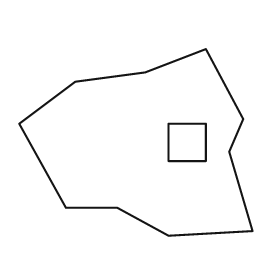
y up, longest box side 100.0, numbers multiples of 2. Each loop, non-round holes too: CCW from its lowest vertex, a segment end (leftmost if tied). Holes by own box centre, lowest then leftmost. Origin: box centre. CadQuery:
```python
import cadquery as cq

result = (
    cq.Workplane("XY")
    .moveTo(14.0, -40.0)
    .lineTo(50.0, -38.0)
    .lineTo(40.0, -4.0)
    .lineTo(46.0, 10.0)
    .lineTo(30.0, 40.0)
    .lineTo(4.0, 30.0)
    .lineTo(-26.0, 26.0)
    .lineTo(-50.0, 8.0)
    .lineTo(-30.0, -28.0)
    .lineTo(-8.0, -28.0)
    .close()
    .moveTo(14.0, -8.0)
    .lineTo(30.0, -8.0)
    .lineTo(30.0, 8.0)
    .lineTo(14.0, 8.0)
    .close()
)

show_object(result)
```